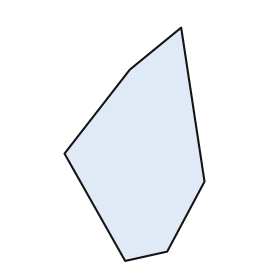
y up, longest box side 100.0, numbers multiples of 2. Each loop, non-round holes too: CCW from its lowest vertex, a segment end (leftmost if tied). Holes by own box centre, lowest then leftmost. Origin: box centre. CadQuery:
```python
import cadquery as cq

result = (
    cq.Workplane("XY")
    .moveTo(-4.0, -50.0)
    .lineTo(14.0, -46.0)
    .lineTo(30.0, -16.0)
    .lineTo(20.0, 50.0)
    .lineTo(-2.0, 32.0)
    .lineTo(-30.0, -4.0)
    .close()
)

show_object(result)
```